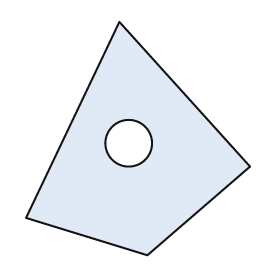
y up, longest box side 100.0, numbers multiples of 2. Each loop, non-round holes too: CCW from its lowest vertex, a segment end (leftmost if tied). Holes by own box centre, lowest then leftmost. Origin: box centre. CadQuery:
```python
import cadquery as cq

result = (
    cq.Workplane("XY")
    .moveTo(4.0, -50.0)
    .lineTo(48.0, -12.0)
    .lineTo(-8.0, 50.0)
    .lineTo(-48.0, -34.0)
    .close()
    .moveTo(-4.0, -2.0)
    .circle(10.0)
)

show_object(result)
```